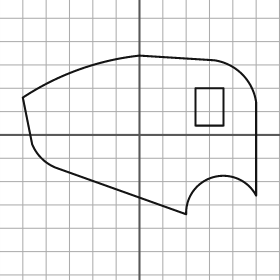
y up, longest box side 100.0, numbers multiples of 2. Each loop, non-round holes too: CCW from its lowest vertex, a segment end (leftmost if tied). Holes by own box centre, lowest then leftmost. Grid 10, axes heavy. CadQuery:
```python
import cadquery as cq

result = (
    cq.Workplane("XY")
    .moveTo(20.0, -34.0)
    .threePointArc((32.0, -18.0), (50.0, -26.0))
    .lineTo(50.0, 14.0)
    .threePointArc((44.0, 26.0), (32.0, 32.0))
    .lineTo(0.0, 34.0)
    .threePointArc((-26.0, 28.0), (-50.0, 16.0))
    .lineTo(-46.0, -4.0)
    .threePointArc((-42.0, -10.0), (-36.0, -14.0))
    .close()
    .moveTo(24.0, 4.0)
    .lineTo(36.0, 4.0)
    .lineTo(36.0, 20.0)
    .lineTo(24.0, 20.0)
    .close()
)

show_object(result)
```